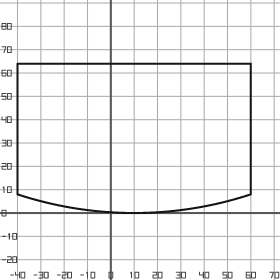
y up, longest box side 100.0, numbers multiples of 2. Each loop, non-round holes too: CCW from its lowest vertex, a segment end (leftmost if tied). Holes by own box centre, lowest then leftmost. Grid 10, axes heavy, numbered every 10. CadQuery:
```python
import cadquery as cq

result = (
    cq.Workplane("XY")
    .moveTo(-40.0, 8.0)
    .threePointArc((10.0, 0.0), (60.0, 8.0))
    .lineTo(60.0, 64.0)
    .lineTo(-40.0, 64.0)
    .close()
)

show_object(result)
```